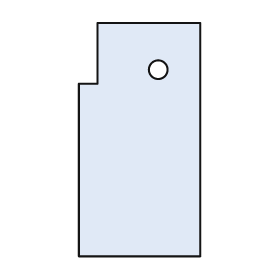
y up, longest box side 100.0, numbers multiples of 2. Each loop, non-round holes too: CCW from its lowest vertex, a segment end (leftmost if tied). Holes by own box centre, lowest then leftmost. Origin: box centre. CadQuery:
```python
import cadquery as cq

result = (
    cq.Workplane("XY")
    .moveTo(-26.0, -50.0)
    .lineTo(26.0, -50.0)
    .lineTo(26.0, 50.0)
    .lineTo(-18.0, 50.0)
    .lineTo(-18.0, 24.0)
    .lineTo(-26.0, 24.0)
    .close()
    .moveTo(8.0, 30.0)
    .circle(4.0)
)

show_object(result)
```